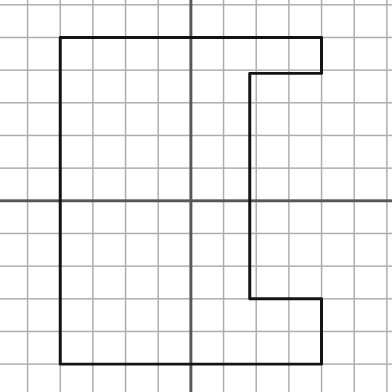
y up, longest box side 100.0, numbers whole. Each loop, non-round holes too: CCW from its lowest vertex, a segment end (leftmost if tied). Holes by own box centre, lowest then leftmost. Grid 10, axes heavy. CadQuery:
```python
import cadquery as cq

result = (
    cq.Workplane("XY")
    .moveTo(-40.0, -50.0)
    .lineTo(40.0, -50.0)
    .lineTo(40.0, -30.0)
    .lineTo(18.0, -30.0)
    .lineTo(18.0, 39.0)
    .lineTo(40.0, 39.0)
    .lineTo(40.0, 50.0)
    .lineTo(-40.0, 50.0)
    .close()
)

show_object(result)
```